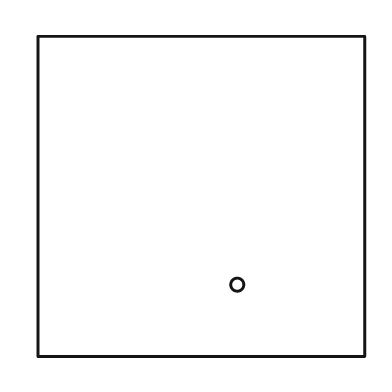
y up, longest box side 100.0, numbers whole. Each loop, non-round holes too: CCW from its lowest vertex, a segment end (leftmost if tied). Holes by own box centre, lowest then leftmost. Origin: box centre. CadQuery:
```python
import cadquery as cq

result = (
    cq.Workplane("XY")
    .moveTo(-50.0, -49.0)
    .lineTo(50.0, -49.0)
    .lineTo(50.0, 49.0)
    .lineTo(-50.0, 49.0)
    .close()
    .moveTo(11.0, -27.0)
    .circle(2.0)
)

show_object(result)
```